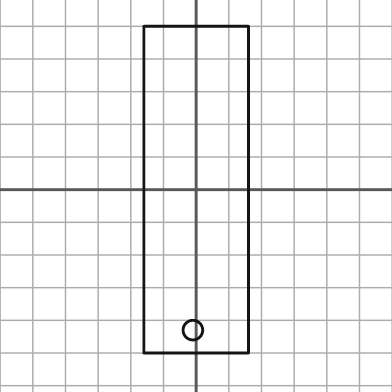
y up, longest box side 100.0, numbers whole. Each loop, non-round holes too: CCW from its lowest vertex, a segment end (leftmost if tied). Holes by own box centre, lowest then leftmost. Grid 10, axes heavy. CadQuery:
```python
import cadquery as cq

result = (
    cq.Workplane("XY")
    .moveTo(-16.0, -50.0)
    .lineTo(16.0, -50.0)
    .lineTo(16.0, 50.0)
    .lineTo(-16.0, 50.0)
    .close()
    .moveTo(-1.0, -43.0)
    .circle(3.0)
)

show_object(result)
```